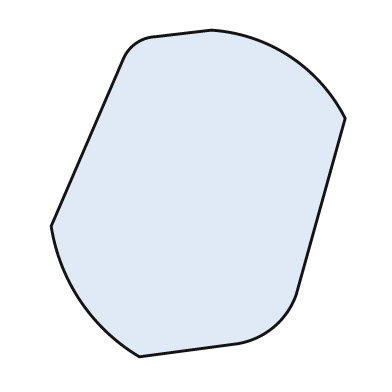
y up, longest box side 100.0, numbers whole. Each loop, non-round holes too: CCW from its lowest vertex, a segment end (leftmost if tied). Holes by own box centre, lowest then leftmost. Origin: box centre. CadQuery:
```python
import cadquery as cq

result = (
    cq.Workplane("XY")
    .moveTo(-18.0, -50.0)
    .lineTo(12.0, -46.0)
    .threePointArc((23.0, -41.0), (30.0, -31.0))
    .lineTo(45.0, 23.0)
    .threePointArc((28.0, 42.0), (4.0, 50.0))
    .lineTo(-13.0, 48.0)
    .threePointArc((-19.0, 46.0), (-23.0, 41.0))
    .lineTo(-45.0, -10.0)
    .threePointArc((-36.0, -33.0), (-18.0, -50.0))
    .close()
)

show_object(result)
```